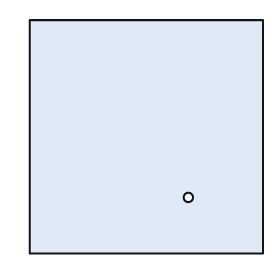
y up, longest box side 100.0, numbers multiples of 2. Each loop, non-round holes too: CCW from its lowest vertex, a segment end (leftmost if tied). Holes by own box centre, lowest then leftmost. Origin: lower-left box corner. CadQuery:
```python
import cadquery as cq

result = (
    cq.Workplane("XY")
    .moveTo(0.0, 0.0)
    .lineTo(100.0, 0.0)
    .lineTo(100.0, 100.0)
    .lineTo(0.0, 100.0)
    .close()
    .moveTo(68.0, 24.0)
    .circle(2.0)
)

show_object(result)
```